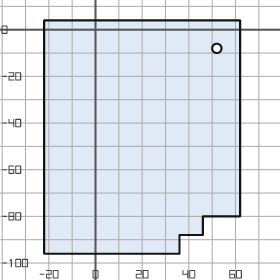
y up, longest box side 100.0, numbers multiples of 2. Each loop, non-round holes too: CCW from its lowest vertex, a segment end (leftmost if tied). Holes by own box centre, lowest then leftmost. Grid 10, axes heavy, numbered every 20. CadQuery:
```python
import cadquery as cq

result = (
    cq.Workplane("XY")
    .moveTo(-22.0, -96.0)
    .lineTo(36.0, -96.0)
    .lineTo(36.0, -88.0)
    .lineTo(46.0, -88.0)
    .lineTo(46.0, -80.0)
    .lineTo(62.0, -80.0)
    .lineTo(62.0, 4.0)
    .lineTo(-22.0, 4.0)
    .close()
    .moveTo(52.0, -8.0)
    .circle(2.0)
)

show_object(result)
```